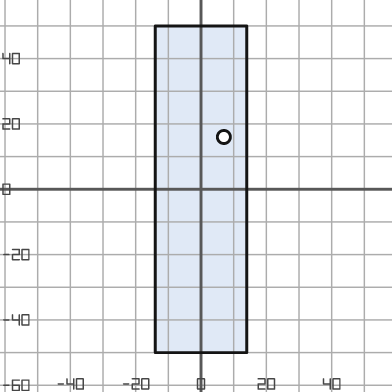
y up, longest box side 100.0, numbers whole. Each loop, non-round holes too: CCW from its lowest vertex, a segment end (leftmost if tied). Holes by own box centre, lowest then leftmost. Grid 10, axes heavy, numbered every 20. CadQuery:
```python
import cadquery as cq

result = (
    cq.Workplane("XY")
    .moveTo(-14.0, -50.0)
    .lineTo(14.0, -50.0)
    .lineTo(14.0, 50.0)
    .lineTo(-14.0, 50.0)
    .close()
    .moveTo(7.0, 16.0)
    .circle(2.0)
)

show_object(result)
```